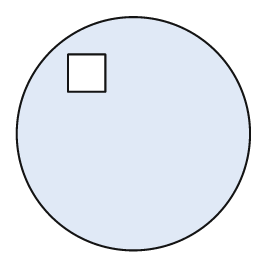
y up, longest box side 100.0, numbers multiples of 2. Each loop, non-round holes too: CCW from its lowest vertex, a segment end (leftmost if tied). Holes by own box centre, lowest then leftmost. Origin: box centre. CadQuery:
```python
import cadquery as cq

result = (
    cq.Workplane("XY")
    .moveTo(0.0, 0.0)
    .circle(50.0)
    .moveTo(-28.0, 18.0)
    .lineTo(-12.0, 18.0)
    .lineTo(-12.0, 34.0)
    .lineTo(-28.0, 34.0)
    .close()
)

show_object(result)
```